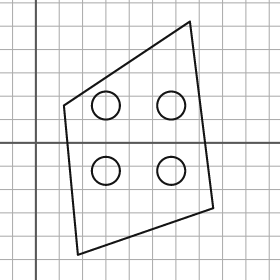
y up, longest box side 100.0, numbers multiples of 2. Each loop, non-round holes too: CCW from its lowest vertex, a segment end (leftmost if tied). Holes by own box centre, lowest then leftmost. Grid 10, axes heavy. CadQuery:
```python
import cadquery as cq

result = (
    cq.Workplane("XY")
    .moveTo(18.0, -48.0)
    .lineTo(76.0, -28.0)
    .lineTo(66.0, 52.0)
    .lineTo(12.0, 16.0)
    .close()
    .moveTo(30.0, -12.0)
    .circle(6.0)
    .moveTo(58.0, -12.0)
    .circle(6.0)
    .moveTo(30.0, 16.0)
    .circle(6.0)
    .moveTo(58.0, 16.0)
    .circle(6.0)
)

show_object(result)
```